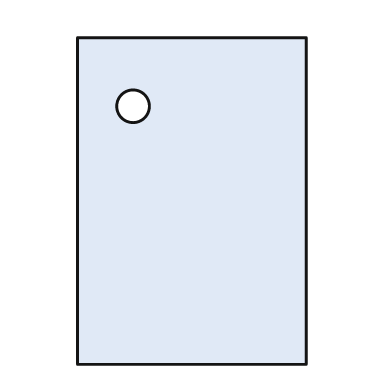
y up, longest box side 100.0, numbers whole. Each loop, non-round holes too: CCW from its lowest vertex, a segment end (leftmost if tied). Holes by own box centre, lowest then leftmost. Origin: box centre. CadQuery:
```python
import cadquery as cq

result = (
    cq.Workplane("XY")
    .moveTo(-35.0, -50.0)
    .lineTo(35.0, -50.0)
    .lineTo(35.0, 50.0)
    .lineTo(-35.0, 50.0)
    .close()
    .moveTo(-18.0, 29.0)
    .circle(5.0)
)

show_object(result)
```